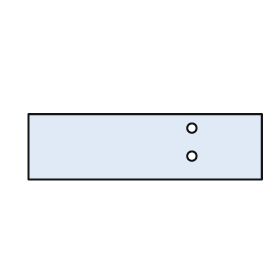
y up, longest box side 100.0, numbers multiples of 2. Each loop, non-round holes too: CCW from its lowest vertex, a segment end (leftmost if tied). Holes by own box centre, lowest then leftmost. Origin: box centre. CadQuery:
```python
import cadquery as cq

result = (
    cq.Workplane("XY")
    .moveTo(-50.0, -14.0)
    .lineTo(50.0, -14.0)
    .lineTo(50.0, 14.0)
    .lineTo(-50.0, 14.0)
    .close()
    .moveTo(20.0, -4.0)
    .circle(2.0)
    .moveTo(20.0, 8.0)
    .circle(2.0)
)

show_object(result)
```